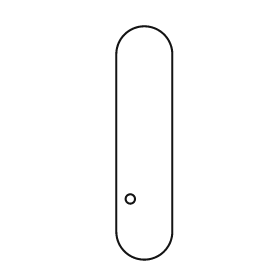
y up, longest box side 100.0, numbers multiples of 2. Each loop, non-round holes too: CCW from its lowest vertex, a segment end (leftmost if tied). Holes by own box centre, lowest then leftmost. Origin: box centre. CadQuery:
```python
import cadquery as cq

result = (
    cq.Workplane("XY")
    .moveTo(-12.0, -38.0)
    .threePointArc((0.0, -50.0), (12.0, -38.0))
    .lineTo(12.0, 38.0)
    .threePointArc((0.0, 50.0), (-12.0, 38.0))
    .close()
    .moveTo(-6.0, -24.0)
    .circle(2.0)
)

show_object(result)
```